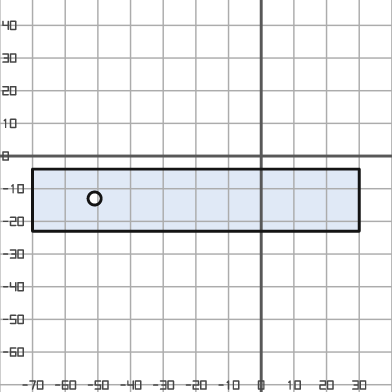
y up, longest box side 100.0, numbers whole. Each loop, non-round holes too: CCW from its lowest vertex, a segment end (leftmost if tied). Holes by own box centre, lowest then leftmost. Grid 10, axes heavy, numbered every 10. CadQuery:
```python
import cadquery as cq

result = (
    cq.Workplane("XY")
    .moveTo(-70.0, -23.0)
    .lineTo(30.0, -23.0)
    .lineTo(30.0, -4.0)
    .lineTo(-70.0, -4.0)
    .close()
    .moveTo(-51.0, -13.0)
    .circle(2.0)
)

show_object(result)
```